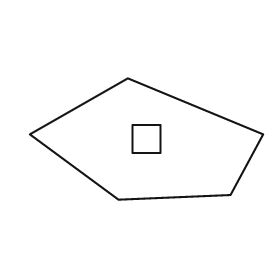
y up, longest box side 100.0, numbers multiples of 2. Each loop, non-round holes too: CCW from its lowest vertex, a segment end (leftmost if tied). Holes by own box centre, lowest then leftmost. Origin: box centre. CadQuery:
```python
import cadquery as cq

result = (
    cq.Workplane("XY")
    .moveTo(-12.0, -26.0)
    .lineTo(36.0, -24.0)
    .lineTo(50.0, 2.0)
    .lineTo(-8.0, 26.0)
    .lineTo(-50.0, 2.0)
    .close()
    .moveTo(-6.0, -6.0)
    .lineTo(6.0, -6.0)
    .lineTo(6.0, 6.0)
    .lineTo(-6.0, 6.0)
    .close()
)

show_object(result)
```